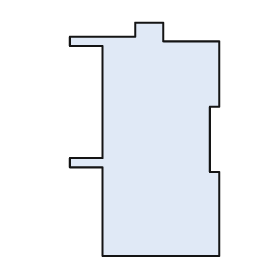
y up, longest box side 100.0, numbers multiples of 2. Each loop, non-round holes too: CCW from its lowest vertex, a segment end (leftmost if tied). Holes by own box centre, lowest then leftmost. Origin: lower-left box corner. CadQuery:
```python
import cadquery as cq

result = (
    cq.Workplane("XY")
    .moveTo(14.0, 0.0)
    .lineTo(64.0, 0.0)
    .lineTo(64.0, 36.0)
    .lineTo(60.0, 36.0)
    .lineTo(60.0, 64.0)
    .lineTo(64.0, 64.0)
    .lineTo(64.0, 92.0)
    .lineTo(40.0, 92.0)
    .lineTo(40.0, 100.0)
    .lineTo(28.0, 100.0)
    .lineTo(28.0, 94.0)
    .lineTo(0.0, 94.0)
    .lineTo(0.0, 90.0)
    .lineTo(14.0, 90.0)
    .lineTo(14.0, 42.0)
    .lineTo(0.0, 42.0)
    .lineTo(0.0, 38.0)
    .lineTo(14.0, 38.0)
    .close()
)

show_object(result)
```